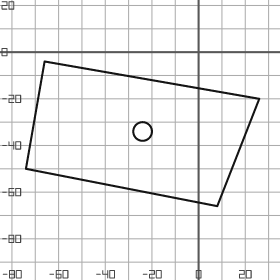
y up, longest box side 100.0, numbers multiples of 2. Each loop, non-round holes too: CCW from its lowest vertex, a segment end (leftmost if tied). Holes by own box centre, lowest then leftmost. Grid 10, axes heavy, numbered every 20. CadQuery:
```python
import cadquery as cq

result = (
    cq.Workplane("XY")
    .moveTo(8.0, -66.0)
    .lineTo(26.0, -20.0)
    .lineTo(-66.0, -4.0)
    .lineTo(-74.0, -50.0)
    .close()
    .moveTo(-24.0, -34.0)
    .circle(4.0)
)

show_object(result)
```